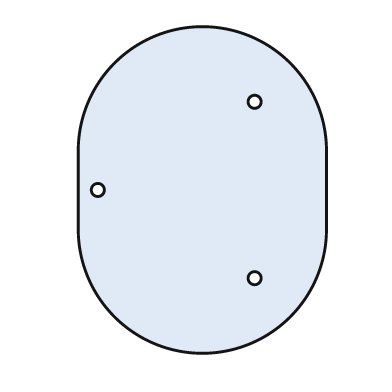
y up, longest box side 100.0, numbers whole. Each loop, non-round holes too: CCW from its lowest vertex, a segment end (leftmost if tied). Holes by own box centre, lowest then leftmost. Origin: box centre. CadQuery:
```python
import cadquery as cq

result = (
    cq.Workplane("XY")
    .moveTo(-38.0, -12.0)
    .threePointArc((0.0, -50.0), (38.0, -12.0))
    .lineTo(38.0, 12.0)
    .threePointArc((0.0, 50.0), (-38.0, 12.0))
    .close()
    .moveTo(16.0, -27.0)
    .circle(2.0)
    .moveTo(-32.0, 0.0)
    .circle(2.0)
    .moveTo(16.0, 27.0)
    .circle(2.0)
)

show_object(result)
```